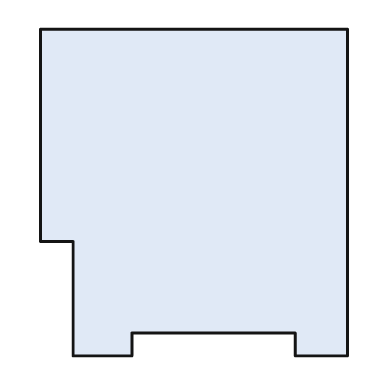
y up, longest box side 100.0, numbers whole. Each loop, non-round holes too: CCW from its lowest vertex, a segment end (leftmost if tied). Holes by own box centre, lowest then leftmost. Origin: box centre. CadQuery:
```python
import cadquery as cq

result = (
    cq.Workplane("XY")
    .moveTo(-37.0, -50.0)
    .lineTo(-19.0, -50.0)
    .lineTo(-19.0, -43.0)
    .lineTo(31.0, -43.0)
    .lineTo(31.0, -50.0)
    .lineTo(47.0, -50.0)
    .lineTo(47.0, 50.0)
    .lineTo(-47.0, 50.0)
    .lineTo(-47.0, -15.0)
    .lineTo(-37.0, -15.0)
    .close()
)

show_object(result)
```